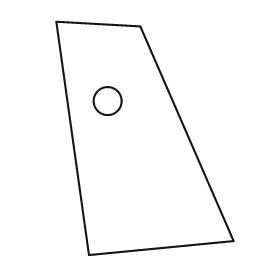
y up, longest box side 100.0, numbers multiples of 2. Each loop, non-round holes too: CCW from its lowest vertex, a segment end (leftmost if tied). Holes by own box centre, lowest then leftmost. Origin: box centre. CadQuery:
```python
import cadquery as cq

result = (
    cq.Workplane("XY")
    .moveTo(-24.0, -50.0)
    .lineTo(38.0, -44.0)
    .lineTo(-2.0, 48.0)
    .lineTo(-38.0, 50.0)
    .close()
    .moveTo(-16.0, 16.0)
    .circle(6.0)
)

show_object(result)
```